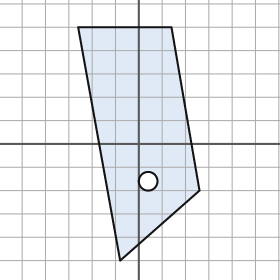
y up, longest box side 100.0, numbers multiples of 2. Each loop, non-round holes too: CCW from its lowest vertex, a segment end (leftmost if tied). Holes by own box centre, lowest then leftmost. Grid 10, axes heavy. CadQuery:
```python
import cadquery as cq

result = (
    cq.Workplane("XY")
    .moveTo(-8.0, -50.0)
    .lineTo(26.0, -20.0)
    .lineTo(14.0, 50.0)
    .lineTo(-26.0, 50.0)
    .close()
    .moveTo(4.0, -16.0)
    .circle(4.0)
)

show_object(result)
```